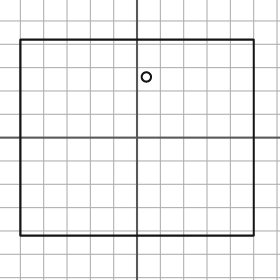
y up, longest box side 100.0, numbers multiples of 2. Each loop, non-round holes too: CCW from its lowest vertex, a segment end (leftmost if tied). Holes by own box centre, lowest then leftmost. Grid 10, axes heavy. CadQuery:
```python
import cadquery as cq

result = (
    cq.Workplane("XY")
    .moveTo(-50.0, -42.0)
    .lineTo(50.0, -42.0)
    .lineTo(50.0, 42.0)
    .lineTo(-50.0, 42.0)
    .close()
    .moveTo(4.0, 26.0)
    .circle(2.0)
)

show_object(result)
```